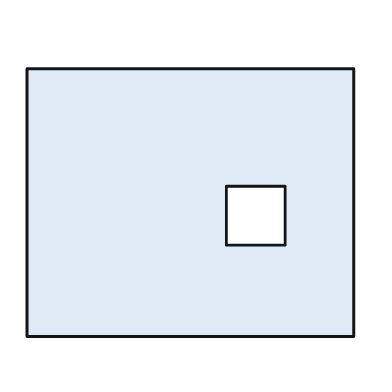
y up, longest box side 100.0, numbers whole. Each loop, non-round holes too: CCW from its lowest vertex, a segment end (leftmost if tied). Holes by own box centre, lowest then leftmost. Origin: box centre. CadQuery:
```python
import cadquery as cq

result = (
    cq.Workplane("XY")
    .moveTo(-50.0, -41.0)
    .lineTo(50.0, -41.0)
    .lineTo(50.0, 41.0)
    .lineTo(-50.0, 41.0)
    .close()
    .moveTo(11.0, -13.0)
    .lineTo(29.0, -13.0)
    .lineTo(29.0, 5.0)
    .lineTo(11.0, 5.0)
    .close()
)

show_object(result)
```